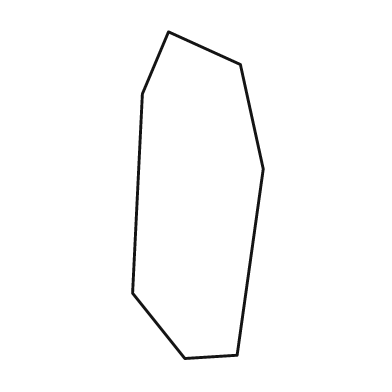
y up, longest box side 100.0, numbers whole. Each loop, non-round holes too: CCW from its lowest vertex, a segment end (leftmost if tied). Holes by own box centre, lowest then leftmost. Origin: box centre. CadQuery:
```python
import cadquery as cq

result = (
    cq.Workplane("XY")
    .moveTo(-4.0, -50.0)
    .lineTo(12.0, -49.0)
    .lineTo(20.0, 8.0)
    .lineTo(13.0, 40.0)
    .lineTo(-9.0, 50.0)
    .lineTo(-17.0, 31.0)
    .lineTo(-20.0, -30.0)
    .close()
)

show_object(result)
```